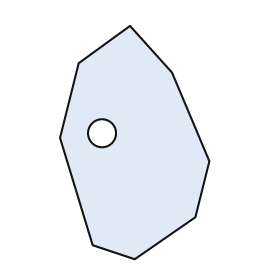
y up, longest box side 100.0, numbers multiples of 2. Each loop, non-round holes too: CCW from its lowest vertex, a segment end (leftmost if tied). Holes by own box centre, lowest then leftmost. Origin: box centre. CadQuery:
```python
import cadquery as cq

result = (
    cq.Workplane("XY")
    .moveTo(0.0, -50.0)
    .lineTo(26.0, -32.0)
    .lineTo(32.0, -8.0)
    .lineTo(16.0, 30.0)
    .lineTo(-2.0, 50.0)
    .lineTo(-24.0, 34.0)
    .lineTo(-32.0, 2.0)
    .lineTo(-18.0, -44.0)
    .close()
    .moveTo(-14.0, 4.0)
    .circle(6.0)
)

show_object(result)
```